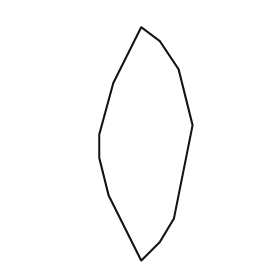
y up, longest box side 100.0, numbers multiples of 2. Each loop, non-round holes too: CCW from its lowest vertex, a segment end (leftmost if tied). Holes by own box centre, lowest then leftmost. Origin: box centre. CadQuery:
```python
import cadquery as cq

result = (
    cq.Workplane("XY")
    .moveTo(-2.0, -50.0)
    .lineTo(6.0, -42.0)
    .lineTo(12.0, -32.0)
    .lineTo(20.0, 8.0)
    .lineTo(14.0, 32.0)
    .lineTo(6.0, 44.0)
    .lineTo(-2.0, 50.0)
    .lineTo(-14.0, 26.0)
    .lineTo(-20.0, 4.0)
    .lineTo(-20.0, -6.0)
    .lineTo(-16.0, -22.0)
    .close()
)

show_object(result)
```